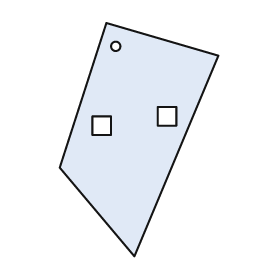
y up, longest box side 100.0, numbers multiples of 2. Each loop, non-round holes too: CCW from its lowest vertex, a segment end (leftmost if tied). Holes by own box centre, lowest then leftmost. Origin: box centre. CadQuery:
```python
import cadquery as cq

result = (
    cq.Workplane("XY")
    .moveTo(-2.0, -50.0)
    .lineTo(34.0, 36.0)
    .lineTo(-14.0, 50.0)
    .lineTo(-34.0, -12.0)
    .close()
    .moveTo(-20.0, 2.0)
    .lineTo(-12.0, 2.0)
    .lineTo(-12.0, 10.0)
    .lineTo(-20.0, 10.0)
    .close()
    .moveTo(8.0, 6.0)
    .lineTo(16.0, 6.0)
    .lineTo(16.0, 14.0)
    .lineTo(8.0, 14.0)
    .close()
    .moveTo(-10.0, 40.0)
    .circle(2.0)
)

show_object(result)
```